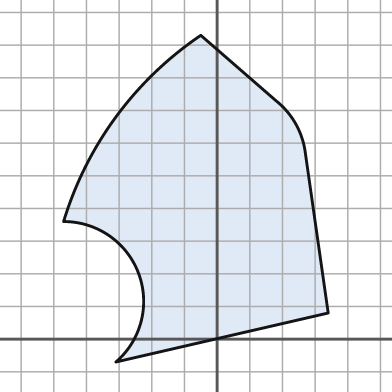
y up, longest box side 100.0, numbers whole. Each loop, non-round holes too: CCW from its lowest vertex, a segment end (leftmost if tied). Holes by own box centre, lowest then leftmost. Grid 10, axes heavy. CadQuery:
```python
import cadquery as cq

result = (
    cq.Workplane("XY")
    .moveTo(-31.0, -7.0)
    .lineTo(34.0, 8.0)
    .lineTo(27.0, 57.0)
    .threePointArc((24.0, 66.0), (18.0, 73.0))
    .lineTo(-5.0, 93.0)
    .threePointArc((-31.0, 68.0), (-47.0, 36.0))
    .threePointArc((-24.0, 20.0), (-31.0, -7.0))
    .close()
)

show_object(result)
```